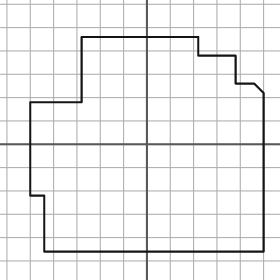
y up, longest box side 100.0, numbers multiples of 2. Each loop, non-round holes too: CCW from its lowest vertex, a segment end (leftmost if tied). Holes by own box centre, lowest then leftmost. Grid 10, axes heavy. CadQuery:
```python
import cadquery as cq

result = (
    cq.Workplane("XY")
    .moveTo(-44.0, -46.0)
    .lineTo(50.0, -46.0)
    .lineTo(50.0, 22.0)
    .lineTo(46.0, 26.0)
    .lineTo(38.0, 26.0)
    .lineTo(38.0, 38.0)
    .lineTo(22.0, 38.0)
    .lineTo(22.0, 46.0)
    .lineTo(-28.0, 46.0)
    .lineTo(-28.0, 18.0)
    .lineTo(-50.0, 18.0)
    .lineTo(-50.0, -22.0)
    .lineTo(-44.0, -22.0)
    .close()
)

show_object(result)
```